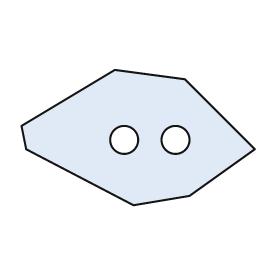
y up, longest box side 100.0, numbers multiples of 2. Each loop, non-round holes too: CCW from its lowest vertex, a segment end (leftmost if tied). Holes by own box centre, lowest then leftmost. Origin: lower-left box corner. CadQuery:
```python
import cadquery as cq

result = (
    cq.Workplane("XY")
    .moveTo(48.0, 0.0)
    .lineTo(72.0, 4.0)
    .lineTo(100.0, 24.0)
    .lineTo(70.0, 54.0)
    .lineTo(40.0, 58.0)
    .lineTo(0.0, 34.0)
    .lineTo(2.0, 24.0)
    .close()
    .moveTo(44.0, 28.0)
    .circle(6.0)
    .moveTo(66.0, 28.0)
    .circle(6.0)
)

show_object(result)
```